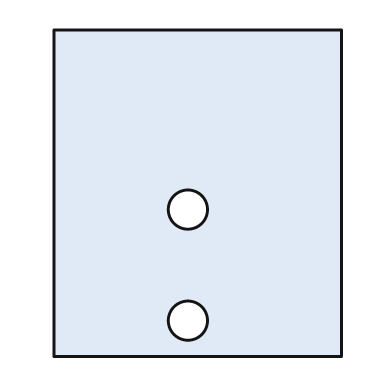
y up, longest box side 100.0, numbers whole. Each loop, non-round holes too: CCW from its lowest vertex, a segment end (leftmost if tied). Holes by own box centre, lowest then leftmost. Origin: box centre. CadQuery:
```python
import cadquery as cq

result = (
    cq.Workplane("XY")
    .moveTo(-44.0, -50.0)
    .lineTo(44.0, -50.0)
    .lineTo(44.0, 50.0)
    .lineTo(-44.0, 50.0)
    .close()
    .moveTo(-3.0, -39.0)
    .circle(6.0)
    .moveTo(-3.0, -5.0)
    .circle(6.0)
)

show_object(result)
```